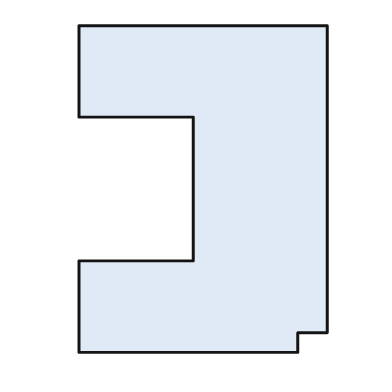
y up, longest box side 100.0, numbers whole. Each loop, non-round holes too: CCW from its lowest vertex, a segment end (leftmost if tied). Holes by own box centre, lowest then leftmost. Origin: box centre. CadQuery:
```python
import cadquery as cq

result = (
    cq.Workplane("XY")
    .moveTo(-38.0, -50.0)
    .lineTo(29.0, -50.0)
    .lineTo(29.0, -44.0)
    .lineTo(38.0, -44.0)
    .lineTo(38.0, 50.0)
    .lineTo(-38.0, 50.0)
    .lineTo(-38.0, 22.0)
    .lineTo(-3.0, 22.0)
    .lineTo(-3.0, -22.0)
    .lineTo(-38.0, -22.0)
    .close()
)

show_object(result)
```